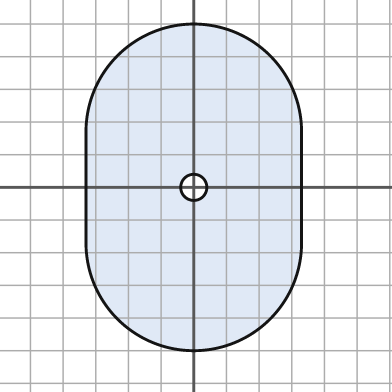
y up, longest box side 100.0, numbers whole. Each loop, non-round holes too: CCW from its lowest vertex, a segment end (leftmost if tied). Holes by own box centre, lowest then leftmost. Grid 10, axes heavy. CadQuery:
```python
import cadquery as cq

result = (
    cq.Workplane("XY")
    .moveTo(-33.0, -17.0)
    .threePointArc((0.0, -50.0), (33.0, -17.0))
    .lineTo(33.0, 17.0)
    .threePointArc((0.0, 50.0), (-33.0, 17.0))
    .close()
    .moveTo(0.0, 0.0)
    .circle(4.0)
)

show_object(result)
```